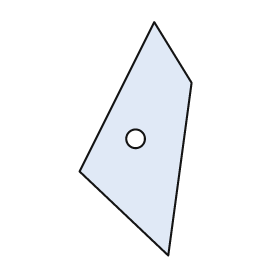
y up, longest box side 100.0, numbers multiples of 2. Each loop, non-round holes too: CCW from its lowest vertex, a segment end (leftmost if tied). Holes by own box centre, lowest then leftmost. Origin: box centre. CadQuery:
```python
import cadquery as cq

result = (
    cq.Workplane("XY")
    .moveTo(14.0, -50.0)
    .lineTo(24.0, 24.0)
    .lineTo(8.0, 50.0)
    .lineTo(-24.0, -14.0)
    .close()
    .moveTo(0.0, 0.0)
    .circle(4.0)
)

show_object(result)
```